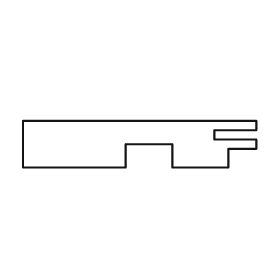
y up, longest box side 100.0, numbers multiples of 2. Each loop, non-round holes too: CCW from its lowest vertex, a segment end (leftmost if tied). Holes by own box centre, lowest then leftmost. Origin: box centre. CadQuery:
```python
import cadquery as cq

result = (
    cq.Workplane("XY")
    .moveTo(-50.0, -10.0)
    .lineTo(-6.0, -10.0)
    .lineTo(-6.0, 0.0)
    .lineTo(14.0, 0.0)
    .lineTo(14.0, -10.0)
    .lineTo(38.0, -10.0)
    .lineTo(38.0, -2.0)
    .lineTo(50.0, -2.0)
    .lineTo(50.0, 2.0)
    .lineTo(32.0, 2.0)
    .lineTo(32.0, 6.0)
    .lineTo(50.0, 6.0)
    .lineTo(50.0, 10.0)
    .lineTo(-50.0, 10.0)
    .close()
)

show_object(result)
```